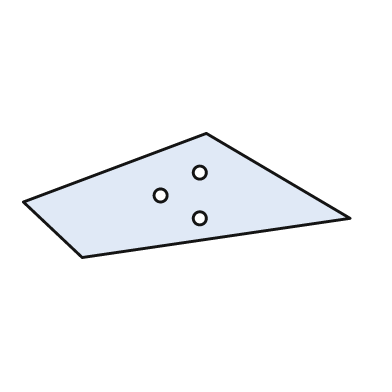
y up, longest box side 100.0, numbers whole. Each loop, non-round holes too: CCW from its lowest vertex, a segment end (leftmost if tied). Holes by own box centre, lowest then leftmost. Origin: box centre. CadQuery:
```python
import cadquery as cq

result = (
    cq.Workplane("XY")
    .moveTo(-32.0, -19.0)
    .lineTo(50.0, -7.0)
    .lineTo(6.0, 19.0)
    .lineTo(-50.0, -2.0)
    .close()
    .moveTo(4.0, -7.0)
    .circle(2.0)
    .moveTo(-8.0, 0.0)
    .circle(2.0)
    .moveTo(4.0, 7.0)
    .circle(2.0)
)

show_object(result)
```